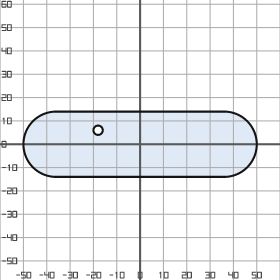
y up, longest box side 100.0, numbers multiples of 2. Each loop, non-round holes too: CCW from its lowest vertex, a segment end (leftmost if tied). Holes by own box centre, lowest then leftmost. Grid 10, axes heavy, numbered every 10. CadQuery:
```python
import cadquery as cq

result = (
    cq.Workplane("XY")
    .moveTo(-36.0, -14.0)
    .lineTo(36.0, -14.0)
    .threePointArc((50.0, 0.0), (36.0, 14.0))
    .lineTo(-36.0, 14.0)
    .threePointArc((-50.0, 0.0), (-36.0, -14.0))
    .close()
    .moveTo(-18.0, 6.0)
    .circle(2.0)
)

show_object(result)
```